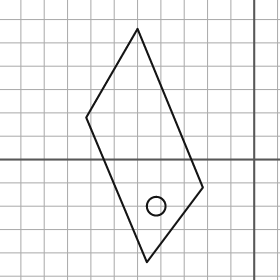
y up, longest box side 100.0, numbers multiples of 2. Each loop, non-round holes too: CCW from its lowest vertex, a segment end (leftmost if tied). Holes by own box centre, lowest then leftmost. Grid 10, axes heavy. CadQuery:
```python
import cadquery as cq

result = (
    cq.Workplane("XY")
    .moveTo(-46.0, -44.0)
    .lineTo(-22.0, -12.0)
    .lineTo(-50.0, 56.0)
    .lineTo(-72.0, 18.0)
    .close()
    .moveTo(-42.0, -20.0)
    .circle(4.0)
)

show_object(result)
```